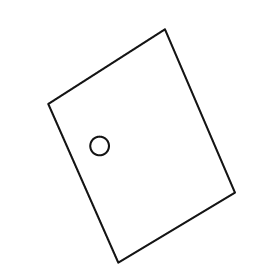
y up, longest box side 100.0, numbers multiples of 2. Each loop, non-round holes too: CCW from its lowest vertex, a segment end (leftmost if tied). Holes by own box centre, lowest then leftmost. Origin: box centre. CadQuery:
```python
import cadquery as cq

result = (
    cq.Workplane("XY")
    .moveTo(-10.0, -50.0)
    .lineTo(40.0, -20.0)
    .lineTo(10.0, 50.0)
    .lineTo(-40.0, 18.0)
    .close()
    .moveTo(-18.0, 0.0)
    .circle(4.0)
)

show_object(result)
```